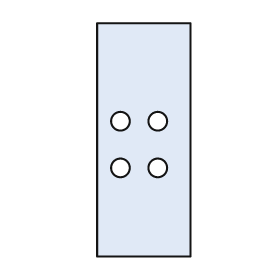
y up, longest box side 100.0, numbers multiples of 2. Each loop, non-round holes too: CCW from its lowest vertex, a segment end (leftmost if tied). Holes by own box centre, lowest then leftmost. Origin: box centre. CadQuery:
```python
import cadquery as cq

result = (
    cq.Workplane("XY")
    .moveTo(-20.0, -50.0)
    .lineTo(20.0, -50.0)
    .lineTo(20.0, 50.0)
    .lineTo(-20.0, 50.0)
    .close()
    .moveTo(-10.0, -12.0)
    .circle(4.0)
    .moveTo(6.0, -12.0)
    .circle(4.0)
    .moveTo(-10.0, 8.0)
    .circle(4.0)
    .moveTo(6.0, 8.0)
    .circle(4.0)
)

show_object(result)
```